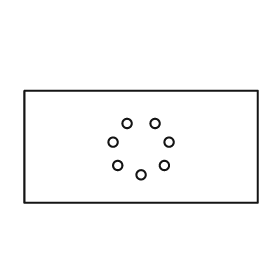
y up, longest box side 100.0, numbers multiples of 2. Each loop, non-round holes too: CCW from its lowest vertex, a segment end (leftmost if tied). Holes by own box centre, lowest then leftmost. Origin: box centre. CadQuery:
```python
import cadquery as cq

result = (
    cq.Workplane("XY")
    .moveTo(-50.0, -24.0)
    .lineTo(50.0, -24.0)
    .lineTo(50.0, 24.0)
    .lineTo(-50.0, 24.0)
    .close()
    .moveTo(0.0, -12.0)
    .circle(2.0)
    .moveTo(-10.0, -8.0)
    .circle(2.0)
    .moveTo(10.0, -8.0)
    .circle(2.0)
    .moveTo(-12.0, 2.0)
    .circle(2.0)
    .moveTo(12.0, 2.0)
    .circle(2.0)
    .moveTo(-6.0, 10.0)
    .circle(2.0)
    .moveTo(6.0, 10.0)
    .circle(2.0)
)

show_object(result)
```